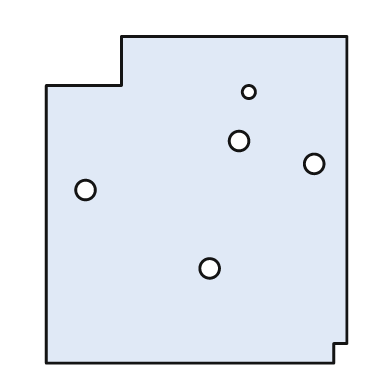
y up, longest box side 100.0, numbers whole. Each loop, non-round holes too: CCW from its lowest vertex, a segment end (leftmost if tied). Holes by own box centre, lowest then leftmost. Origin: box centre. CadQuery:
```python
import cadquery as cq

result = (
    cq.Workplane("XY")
    .moveTo(-46.0, -50.0)
    .lineTo(42.0, -50.0)
    .lineTo(42.0, -44.0)
    .lineTo(46.0, -44.0)
    .lineTo(46.0, 50.0)
    .lineTo(-23.0, 50.0)
    .lineTo(-23.0, 35.0)
    .lineTo(-46.0, 35.0)
    .close()
    .moveTo(4.0, -21.0)
    .circle(3.0)
    .moveTo(-34.0, 3.0)
    .circle(3.0)
    .moveTo(36.0, 11.0)
    .circle(3.0)
    .moveTo(13.0, 18.0)
    .circle(3.0)
    .moveTo(16.0, 33.0)
    .circle(2.0)
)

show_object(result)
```